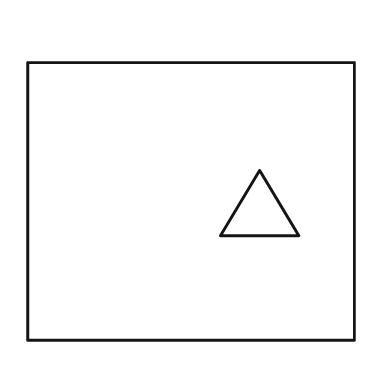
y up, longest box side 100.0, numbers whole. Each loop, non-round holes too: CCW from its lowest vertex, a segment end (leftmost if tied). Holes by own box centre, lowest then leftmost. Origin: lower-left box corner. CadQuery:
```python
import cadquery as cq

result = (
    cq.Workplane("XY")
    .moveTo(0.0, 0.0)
    .lineTo(100.0, 0.0)
    .lineTo(100.0, 85.0)
    .lineTo(0.0, 85.0)
    .close()
    .moveTo(59.0, 32.0)
    .lineTo(83.0, 32.0)
    .lineTo(71.0, 52.0)
    .close()
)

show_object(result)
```